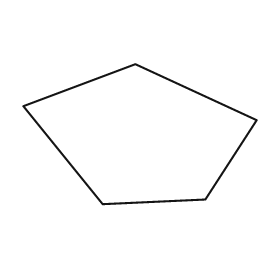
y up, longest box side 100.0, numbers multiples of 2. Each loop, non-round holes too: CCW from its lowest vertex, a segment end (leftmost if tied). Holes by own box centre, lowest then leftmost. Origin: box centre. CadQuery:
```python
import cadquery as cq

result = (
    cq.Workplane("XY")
    .moveTo(-16.0, -30.0)
    .lineTo(28.0, -28.0)
    .lineTo(50.0, 6.0)
    .lineTo(-2.0, 30.0)
    .lineTo(-50.0, 12.0)
    .close()
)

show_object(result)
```